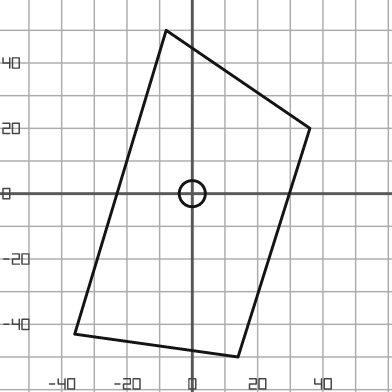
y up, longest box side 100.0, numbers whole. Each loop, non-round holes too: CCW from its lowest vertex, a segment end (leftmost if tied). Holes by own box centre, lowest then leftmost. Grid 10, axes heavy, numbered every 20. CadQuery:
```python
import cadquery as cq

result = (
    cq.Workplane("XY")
    .moveTo(14.0, -50.0)
    .lineTo(36.0, 20.0)
    .lineTo(-8.0, 50.0)
    .lineTo(-36.0, -43.0)
    .close()
    .moveTo(0.0, 0.0)
    .circle(4.0)
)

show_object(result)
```